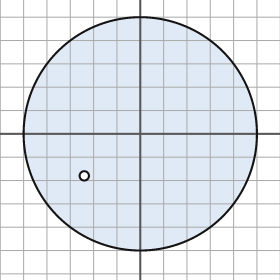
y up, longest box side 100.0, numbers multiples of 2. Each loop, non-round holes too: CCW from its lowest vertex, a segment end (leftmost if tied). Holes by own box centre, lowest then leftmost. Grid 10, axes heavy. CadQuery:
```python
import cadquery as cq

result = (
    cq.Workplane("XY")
    .moveTo(0.0, 0.0)
    .circle(50.0)
    .moveTo(-24.0, -18.0)
    .circle(2.0)
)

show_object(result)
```